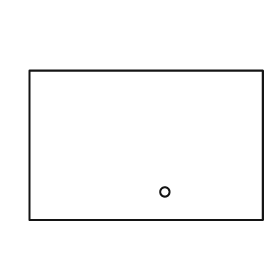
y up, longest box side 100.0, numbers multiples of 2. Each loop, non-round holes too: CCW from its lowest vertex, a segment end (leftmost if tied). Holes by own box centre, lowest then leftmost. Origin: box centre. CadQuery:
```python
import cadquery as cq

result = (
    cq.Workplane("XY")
    .moveTo(-50.0, -32.0)
    .lineTo(50.0, -32.0)
    .lineTo(50.0, 32.0)
    .lineTo(-50.0, 32.0)
    .close()
    .moveTo(8.0, -20.0)
    .circle(2.0)
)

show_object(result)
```